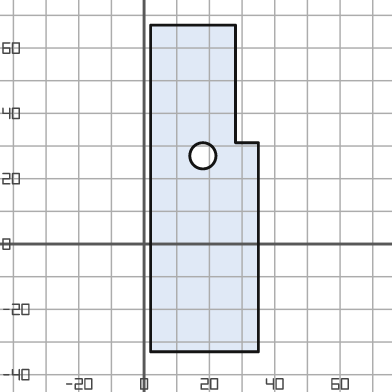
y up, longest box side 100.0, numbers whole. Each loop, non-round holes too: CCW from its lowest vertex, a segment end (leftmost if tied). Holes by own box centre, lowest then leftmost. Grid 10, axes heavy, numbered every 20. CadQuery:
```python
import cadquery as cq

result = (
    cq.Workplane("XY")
    .moveTo(2.0, -33.0)
    .lineTo(35.0, -33.0)
    .lineTo(35.0, 31.0)
    .lineTo(28.0, 31.0)
    .lineTo(28.0, 67.0)
    .lineTo(2.0, 67.0)
    .close()
    .moveTo(18.0, 27.0)
    .circle(4.0)
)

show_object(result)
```